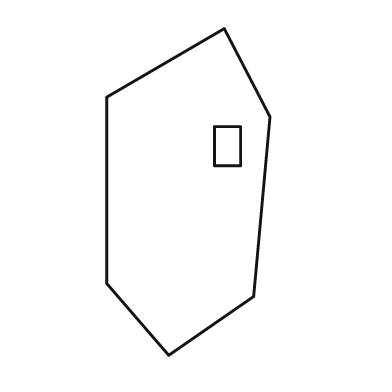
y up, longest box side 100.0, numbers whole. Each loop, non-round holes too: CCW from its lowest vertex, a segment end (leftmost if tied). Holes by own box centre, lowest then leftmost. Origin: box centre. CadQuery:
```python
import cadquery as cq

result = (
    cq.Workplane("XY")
    .moveTo(-6.0, -50.0)
    .lineTo(20.0, -32.0)
    .lineTo(25.0, 23.0)
    .lineTo(11.0, 50.0)
    .lineTo(-25.0, 29.0)
    .lineTo(-25.0, -28.0)
    .close()
    .moveTo(8.0, 8.0)
    .lineTo(16.0, 8.0)
    .lineTo(16.0, 20.0)
    .lineTo(8.0, 20.0)
    .close()
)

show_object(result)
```